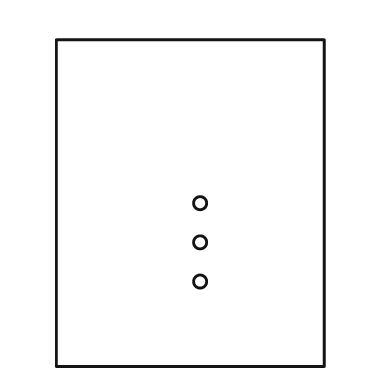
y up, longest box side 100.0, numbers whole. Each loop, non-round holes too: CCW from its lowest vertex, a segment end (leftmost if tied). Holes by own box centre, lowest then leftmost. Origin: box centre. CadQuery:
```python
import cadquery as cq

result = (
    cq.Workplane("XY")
    .moveTo(-41.0, -50.0)
    .lineTo(41.0, -50.0)
    .lineTo(41.0, 50.0)
    .lineTo(-41.0, 50.0)
    .close()
    .moveTo(3.0, -24.0)
    .circle(2.0)
    .moveTo(3.0, -12.0)
    .circle(2.0)
    .moveTo(3.0, 0.0)
    .circle(2.0)
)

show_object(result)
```